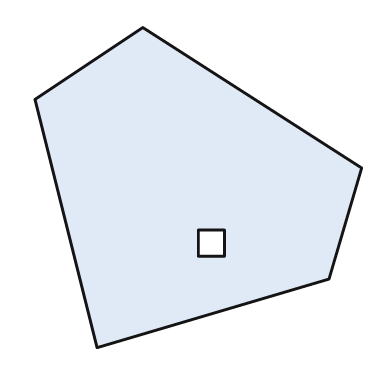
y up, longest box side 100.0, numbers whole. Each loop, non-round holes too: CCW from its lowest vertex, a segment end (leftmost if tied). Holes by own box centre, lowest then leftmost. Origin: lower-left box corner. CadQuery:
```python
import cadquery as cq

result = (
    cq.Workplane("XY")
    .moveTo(19.0, 0.0)
    .lineTo(90.0, 21.0)
    .lineTo(100.0, 55.0)
    .lineTo(33.0, 98.0)
    .lineTo(0.0, 76.0)
    .close()
    .moveTo(50.0, 28.0)
    .lineTo(58.0, 28.0)
    .lineTo(58.0, 36.0)
    .lineTo(50.0, 36.0)
    .close()
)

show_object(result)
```